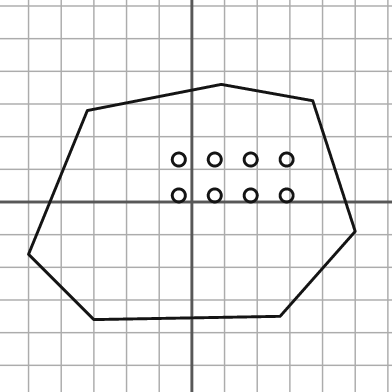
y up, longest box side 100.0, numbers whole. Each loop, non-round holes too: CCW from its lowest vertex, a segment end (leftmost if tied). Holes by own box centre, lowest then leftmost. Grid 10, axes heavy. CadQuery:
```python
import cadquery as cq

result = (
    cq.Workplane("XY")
    .moveTo(-30.0, -36.0)
    .lineTo(27.0, -35.0)
    .lineTo(50.0, -9.0)
    .lineTo(37.0, 31.0)
    .lineTo(9.0, 36.0)
    .lineTo(-32.0, 28.0)
    .lineTo(-50.0, -16.0)
    .close()
    .moveTo(-4.0, 2.0)
    .circle(2.0)
    .moveTo(7.0, 2.0)
    .circle(2.0)
    .moveTo(18.0, 2.0)
    .circle(2.0)
    .moveTo(29.0, 2.0)
    .circle(2.0)
    .moveTo(-4.0, 13.0)
    .circle(2.0)
    .moveTo(7.0, 13.0)
    .circle(2.0)
    .moveTo(18.0, 13.0)
    .circle(2.0)
    .moveTo(29.0, 13.0)
    .circle(2.0)
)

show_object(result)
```